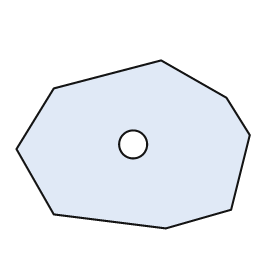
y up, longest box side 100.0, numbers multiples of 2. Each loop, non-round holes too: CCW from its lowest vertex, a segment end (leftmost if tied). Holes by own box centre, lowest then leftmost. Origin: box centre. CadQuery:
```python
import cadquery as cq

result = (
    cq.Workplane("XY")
    .moveTo(14.0, -36.0)
    .lineTo(42.0, -28.0)
    .lineTo(50.0, 4.0)
    .lineTo(40.0, 20.0)
    .lineTo(12.0, 36.0)
    .lineTo(-34.0, 24.0)
    .lineTo(-50.0, -2.0)
    .lineTo(-34.0, -30.0)
    .close()
    .moveTo(0.0, 0.0)
    .circle(6.0)
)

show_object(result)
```